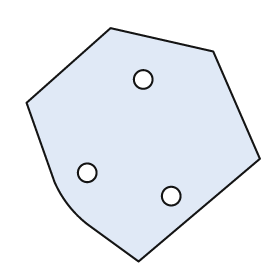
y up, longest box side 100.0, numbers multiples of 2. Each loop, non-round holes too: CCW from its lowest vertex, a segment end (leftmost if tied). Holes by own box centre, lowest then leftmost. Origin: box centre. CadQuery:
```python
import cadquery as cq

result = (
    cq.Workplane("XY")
    .moveTo(-2.0, -50.0)
    .lineTo(50.0, -6.0)
    .lineTo(30.0, 40.0)
    .lineTo(-14.0, 50.0)
    .lineTo(-50.0, 18.0)
    .lineTo(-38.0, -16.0)
    .threePointArc((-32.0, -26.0), (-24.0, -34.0))
    .close()
    .moveTo(12.0, -22.0)
    .circle(4.0)
    .moveTo(-24.0, -12.0)
    .circle(4.0)
    .moveTo(0.0, 28.0)
    .circle(4.0)
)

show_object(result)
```